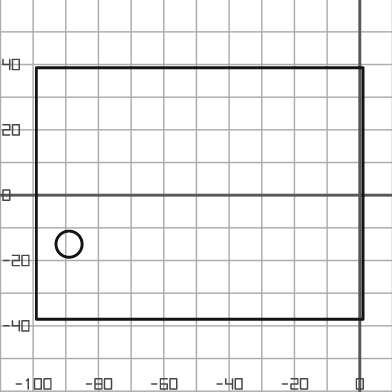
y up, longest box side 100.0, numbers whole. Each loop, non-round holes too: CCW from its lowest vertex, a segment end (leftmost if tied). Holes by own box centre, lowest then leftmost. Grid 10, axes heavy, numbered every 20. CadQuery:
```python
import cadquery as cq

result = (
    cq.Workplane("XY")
    .moveTo(-99.0, -38.0)
    .lineTo(1.0, -38.0)
    .lineTo(1.0, 39.0)
    .lineTo(-99.0, 39.0)
    .close()
    .moveTo(-89.0, -15.0)
    .circle(4.0)
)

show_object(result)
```